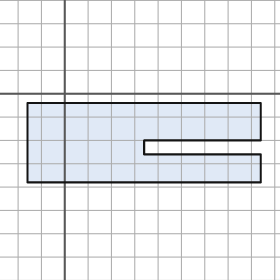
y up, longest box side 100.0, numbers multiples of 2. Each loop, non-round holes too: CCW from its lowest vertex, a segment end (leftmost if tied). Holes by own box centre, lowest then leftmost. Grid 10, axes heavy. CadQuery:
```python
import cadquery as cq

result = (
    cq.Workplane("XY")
    .moveTo(-16.0, -38.0)
    .lineTo(84.0, -38.0)
    .lineTo(84.0, -26.0)
    .lineTo(34.0, -26.0)
    .lineTo(34.0, -20.0)
    .lineTo(84.0, -20.0)
    .lineTo(84.0, -4.0)
    .lineTo(-16.0, -4.0)
    .close()
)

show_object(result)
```